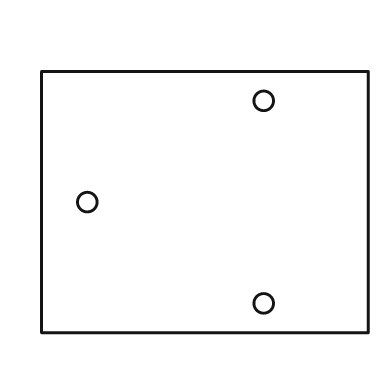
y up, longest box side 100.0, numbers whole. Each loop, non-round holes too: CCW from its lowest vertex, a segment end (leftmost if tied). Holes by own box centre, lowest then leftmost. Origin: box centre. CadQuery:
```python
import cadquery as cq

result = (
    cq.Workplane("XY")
    .moveTo(-50.0, -40.0)
    .lineTo(50.0, -40.0)
    .lineTo(50.0, 40.0)
    .lineTo(-50.0, 40.0)
    .close()
    .moveTo(18.0, -31.0)
    .circle(3.0)
    .moveTo(-36.0, 0.0)
    .circle(3.0)
    .moveTo(18.0, 31.0)
    .circle(3.0)
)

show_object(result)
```